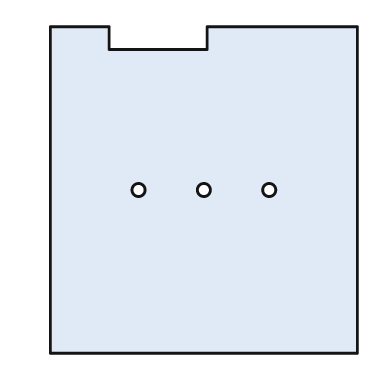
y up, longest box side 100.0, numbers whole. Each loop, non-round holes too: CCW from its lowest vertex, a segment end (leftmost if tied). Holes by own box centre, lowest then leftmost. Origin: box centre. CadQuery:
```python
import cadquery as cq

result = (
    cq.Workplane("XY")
    .moveTo(-47.0, -50.0)
    .lineTo(47.0, -50.0)
    .lineTo(47.0, 50.0)
    .lineTo(1.0, 50.0)
    .lineTo(1.0, 43.0)
    .lineTo(-29.0, 43.0)
    .lineTo(-29.0, 50.0)
    .lineTo(-47.0, 50.0)
    .close()
    .moveTo(-20.0, 0.0)
    .circle(2.0)
    .moveTo(0.0, 0.0)
    .circle(2.0)
    .moveTo(20.0, 0.0)
    .circle(2.0)
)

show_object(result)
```